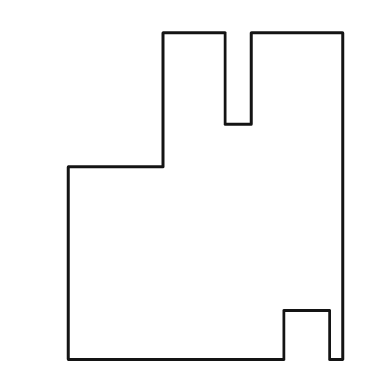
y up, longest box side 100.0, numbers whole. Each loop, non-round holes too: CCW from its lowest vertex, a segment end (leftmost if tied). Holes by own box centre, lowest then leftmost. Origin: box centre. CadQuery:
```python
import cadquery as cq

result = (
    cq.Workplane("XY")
    .moveTo(-42.0, -50.0)
    .lineTo(24.0, -50.0)
    .lineTo(24.0, -35.0)
    .lineTo(38.0, -35.0)
    .lineTo(38.0, -50.0)
    .lineTo(42.0, -50.0)
    .lineTo(42.0, 50.0)
    .lineTo(14.0, 50.0)
    .lineTo(14.0, 22.0)
    .lineTo(6.0, 22.0)
    .lineTo(6.0, 50.0)
    .lineTo(-13.0, 50.0)
    .lineTo(-13.0, 9.0)
    .lineTo(-42.0, 9.0)
    .close()
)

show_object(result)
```